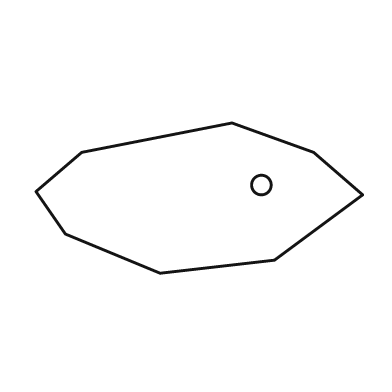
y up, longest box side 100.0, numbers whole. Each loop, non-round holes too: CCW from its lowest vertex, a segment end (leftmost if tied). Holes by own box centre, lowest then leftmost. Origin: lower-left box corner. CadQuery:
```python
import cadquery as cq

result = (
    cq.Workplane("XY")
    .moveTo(38.0, 0.0)
    .lineTo(73.0, 4.0)
    .lineTo(100.0, 24.0)
    .lineTo(85.0, 37.0)
    .lineTo(60.0, 46.0)
    .lineTo(14.0, 37.0)
    .lineTo(0.0, 25.0)
    .lineTo(9.0, 12.0)
    .close()
    .moveTo(69.0, 27.0)
    .circle(3.0)
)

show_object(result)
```